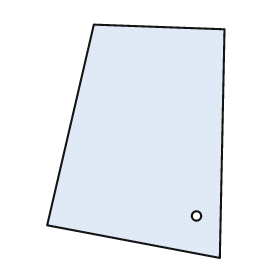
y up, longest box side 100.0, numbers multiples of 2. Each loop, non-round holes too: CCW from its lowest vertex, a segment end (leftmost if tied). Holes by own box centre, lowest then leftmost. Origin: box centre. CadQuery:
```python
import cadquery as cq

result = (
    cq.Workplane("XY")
    .moveTo(36.0, -50.0)
    .lineTo(38.0, 48.0)
    .lineTo(-18.0, 50.0)
    .lineTo(-38.0, -36.0)
    .close()
    .moveTo(26.0, -32.0)
    .circle(2.0)
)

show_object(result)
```